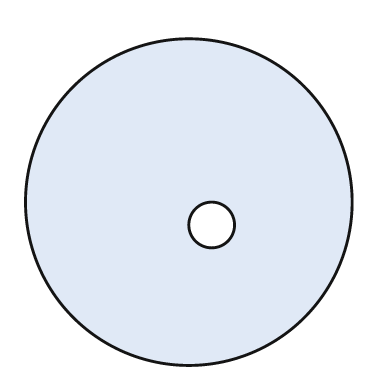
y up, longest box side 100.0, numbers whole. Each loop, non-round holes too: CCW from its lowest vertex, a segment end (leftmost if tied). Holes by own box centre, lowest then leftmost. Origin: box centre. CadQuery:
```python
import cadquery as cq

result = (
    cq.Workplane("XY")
    .moveTo(0.0, 0.0)
    .circle(50.0)
    .moveTo(7.0, -7.0)
    .circle(7.0)
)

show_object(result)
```